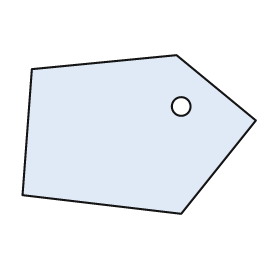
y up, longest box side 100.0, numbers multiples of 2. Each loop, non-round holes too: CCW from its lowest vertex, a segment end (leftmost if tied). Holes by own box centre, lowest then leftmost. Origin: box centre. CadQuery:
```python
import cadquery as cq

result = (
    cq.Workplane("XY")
    .moveTo(18.0, -34.0)
    .lineTo(50.0, 6.0)
    .lineTo(16.0, 34.0)
    .lineTo(-46.0, 28.0)
    .lineTo(-50.0, -26.0)
    .close()
    .moveTo(18.0, 12.0)
    .circle(4.0)
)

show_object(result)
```